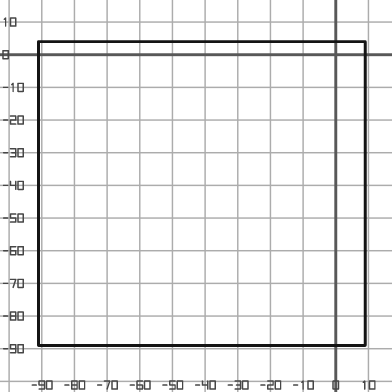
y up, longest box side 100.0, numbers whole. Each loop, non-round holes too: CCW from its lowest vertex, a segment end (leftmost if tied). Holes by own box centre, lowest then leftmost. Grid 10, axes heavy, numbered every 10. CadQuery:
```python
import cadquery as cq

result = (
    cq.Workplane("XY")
    .moveTo(-91.0, -89.0)
    .lineTo(9.0, -89.0)
    .lineTo(9.0, 4.0)
    .lineTo(-91.0, 4.0)
    .close()
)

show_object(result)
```